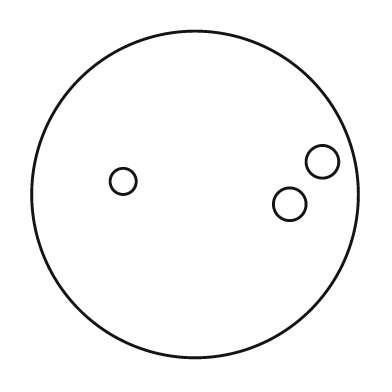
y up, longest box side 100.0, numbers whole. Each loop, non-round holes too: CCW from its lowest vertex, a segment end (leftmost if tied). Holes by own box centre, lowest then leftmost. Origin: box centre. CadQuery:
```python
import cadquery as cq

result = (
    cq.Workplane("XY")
    .moveTo(0.0, 0.0)
    .circle(50.0)
    .moveTo(29.0, -3.0)
    .circle(5.0)
    .moveTo(-22.0, 4.0)
    .circle(4.0)
    .moveTo(39.0, 10.0)
    .circle(5.0)
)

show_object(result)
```